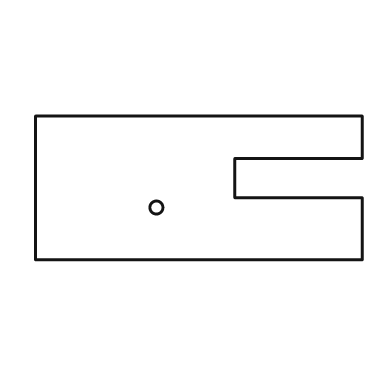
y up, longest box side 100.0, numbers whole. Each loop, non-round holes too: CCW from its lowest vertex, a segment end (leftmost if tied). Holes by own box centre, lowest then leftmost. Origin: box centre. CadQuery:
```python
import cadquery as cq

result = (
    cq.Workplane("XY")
    .moveTo(-50.0, -22.0)
    .lineTo(50.0, -22.0)
    .lineTo(50.0, -3.0)
    .lineTo(11.0, -3.0)
    .lineTo(11.0, 9.0)
    .lineTo(50.0, 9.0)
    .lineTo(50.0, 22.0)
    .lineTo(-50.0, 22.0)
    .close()
    .moveTo(-13.0, -6.0)
    .circle(2.0)
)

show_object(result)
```